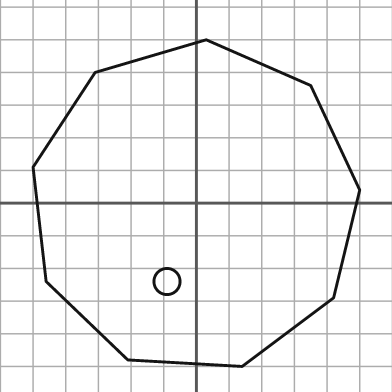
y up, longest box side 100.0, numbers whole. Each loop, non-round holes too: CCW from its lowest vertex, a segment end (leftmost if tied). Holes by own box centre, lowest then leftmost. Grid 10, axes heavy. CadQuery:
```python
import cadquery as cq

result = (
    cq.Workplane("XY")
    .moveTo(14.0, -50.0)
    .lineTo(42.0, -29.0)
    .lineTo(50.0, 4.0)
    .lineTo(35.0, 36.0)
    .lineTo(3.0, 50.0)
    .lineTo(-31.0, 40.0)
    .lineTo(-50.0, 11.0)
    .lineTo(-46.0, -24.0)
    .lineTo(-21.0, -48.0)
    .close()
    .moveTo(-9.0, -24.0)
    .circle(4.0)
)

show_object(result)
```